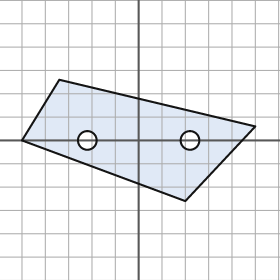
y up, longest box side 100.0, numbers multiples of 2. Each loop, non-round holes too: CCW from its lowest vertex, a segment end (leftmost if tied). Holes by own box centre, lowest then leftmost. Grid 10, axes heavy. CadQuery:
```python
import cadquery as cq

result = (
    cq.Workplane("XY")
    .moveTo(20.0, -26.0)
    .lineTo(50.0, 6.0)
    .lineTo(-34.0, 26.0)
    .lineTo(-50.0, 0.0)
    .close()
    .moveTo(-22.0, 0.0)
    .circle(4.0)
    .moveTo(22.0, 0.0)
    .circle(4.0)
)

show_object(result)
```